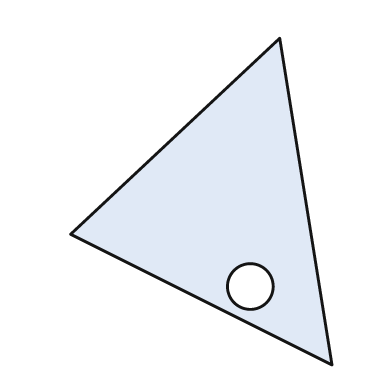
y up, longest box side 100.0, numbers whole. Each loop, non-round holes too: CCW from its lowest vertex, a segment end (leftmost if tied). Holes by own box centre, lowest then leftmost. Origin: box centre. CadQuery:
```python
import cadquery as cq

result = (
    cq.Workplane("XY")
    .moveTo(40.0, -50.0)
    .lineTo(24.0, 50.0)
    .lineTo(-40.0, -10.0)
    .close()
    .moveTo(15.0, -26.0)
    .circle(7.0)
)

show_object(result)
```